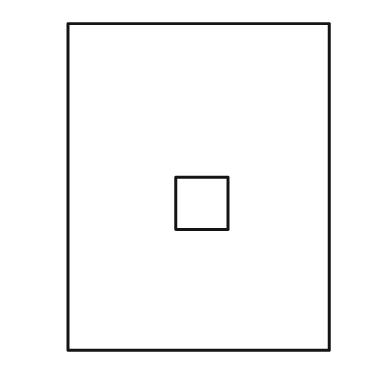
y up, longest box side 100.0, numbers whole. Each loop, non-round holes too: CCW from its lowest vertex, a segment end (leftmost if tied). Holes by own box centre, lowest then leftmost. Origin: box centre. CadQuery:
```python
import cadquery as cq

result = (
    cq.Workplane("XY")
    .moveTo(-40.0, -50.0)
    .lineTo(40.0, -50.0)
    .lineTo(40.0, 50.0)
    .lineTo(-40.0, 50.0)
    .close()
    .moveTo(-7.0, -13.0)
    .lineTo(9.0, -13.0)
    .lineTo(9.0, 3.0)
    .lineTo(-7.0, 3.0)
    .close()
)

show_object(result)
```